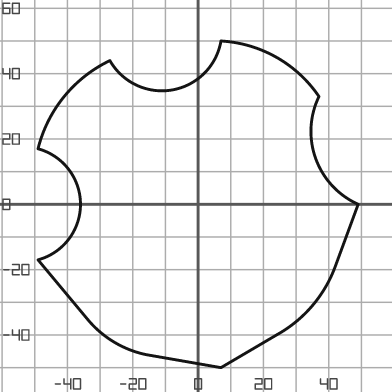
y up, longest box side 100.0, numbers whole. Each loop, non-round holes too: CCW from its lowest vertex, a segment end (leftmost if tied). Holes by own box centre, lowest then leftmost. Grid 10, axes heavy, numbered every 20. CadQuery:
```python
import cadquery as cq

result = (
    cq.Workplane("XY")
    .moveTo(7.0, -50.0)
    .lineTo(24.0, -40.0)
    .threePointArc((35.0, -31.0), (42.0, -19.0))
    .lineTo(49.0, 0.0)
    .threePointArc((36.0, 14.0), (37.0, 33.0))
    .threePointArc((24.0, 45.0), (7.0, 50.0))
    .threePointArc((-8.0, 35.0), (-27.0, 44.0))
    .threePointArc((-41.0, 33.0), (-49.0, 17.0))
    .threePointArc((-36.0, 0.0), (-49.0, -17.0))
    .lineTo(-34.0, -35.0)
    .threePointArc((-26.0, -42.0), (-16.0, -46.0))
    .close()
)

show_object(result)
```